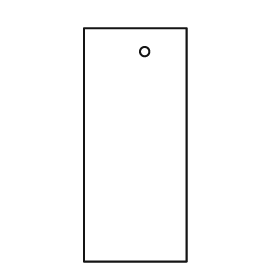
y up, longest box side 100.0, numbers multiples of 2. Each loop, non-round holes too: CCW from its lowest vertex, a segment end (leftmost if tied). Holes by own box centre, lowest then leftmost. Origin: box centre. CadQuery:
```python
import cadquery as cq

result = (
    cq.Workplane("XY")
    .moveTo(-22.0, -50.0)
    .lineTo(22.0, -50.0)
    .lineTo(22.0, 50.0)
    .lineTo(-22.0, 50.0)
    .close()
    .moveTo(4.0, 40.0)
    .circle(2.0)
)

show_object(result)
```